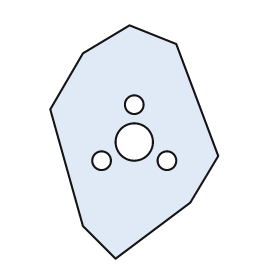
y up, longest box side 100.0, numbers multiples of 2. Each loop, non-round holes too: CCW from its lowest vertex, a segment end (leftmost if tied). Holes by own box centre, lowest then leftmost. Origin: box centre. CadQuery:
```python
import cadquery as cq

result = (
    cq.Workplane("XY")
    .moveTo(-8.0, -50.0)
    .lineTo(24.0, -26.0)
    .lineTo(36.0, -6.0)
    .lineTo(18.0, 42.0)
    .lineTo(-2.0, 50.0)
    .lineTo(-22.0, 38.0)
    .lineTo(-36.0, 14.0)
    .lineTo(-22.0, -36.0)
    .close()
    .moveTo(-14.0, -8.0)
    .circle(4.0)
    .moveTo(14.0, -8.0)
    .circle(4.0)
    .moveTo(0.0, 0.0)
    .circle(8.0)
    .moveTo(0.0, 16.0)
    .circle(4.0)
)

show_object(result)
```